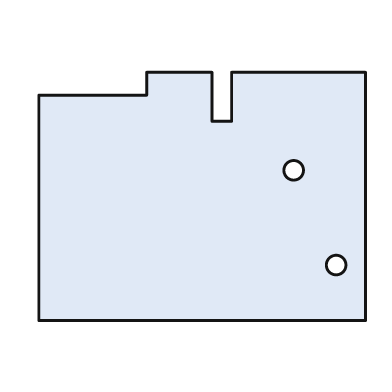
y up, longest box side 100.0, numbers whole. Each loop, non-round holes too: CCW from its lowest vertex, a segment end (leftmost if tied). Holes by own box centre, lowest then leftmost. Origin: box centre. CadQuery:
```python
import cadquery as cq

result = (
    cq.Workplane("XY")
    .moveTo(-50.0, -38.0)
    .lineTo(50.0, -38.0)
    .lineTo(50.0, 38.0)
    .lineTo(9.0, 38.0)
    .lineTo(9.0, 23.0)
    .lineTo(3.0, 23.0)
    .lineTo(3.0, 38.0)
    .lineTo(-17.0, 38.0)
    .lineTo(-17.0, 31.0)
    .lineTo(-50.0, 31.0)
    .close()
    .moveTo(41.0, -21.0)
    .circle(3.0)
    .moveTo(28.0, 8.0)
    .circle(3.0)
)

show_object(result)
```